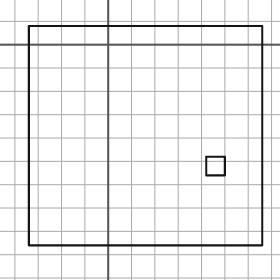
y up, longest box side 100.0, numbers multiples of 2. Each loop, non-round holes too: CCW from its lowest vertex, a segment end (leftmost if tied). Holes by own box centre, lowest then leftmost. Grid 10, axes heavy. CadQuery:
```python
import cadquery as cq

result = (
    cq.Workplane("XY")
    .moveTo(-34.0, -86.0)
    .lineTo(66.0, -86.0)
    .lineTo(66.0, 8.0)
    .lineTo(-34.0, 8.0)
    .close()
    .moveTo(42.0, -56.0)
    .lineTo(50.0, -56.0)
    .lineTo(50.0, -48.0)
    .lineTo(42.0, -48.0)
    .close()
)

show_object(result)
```